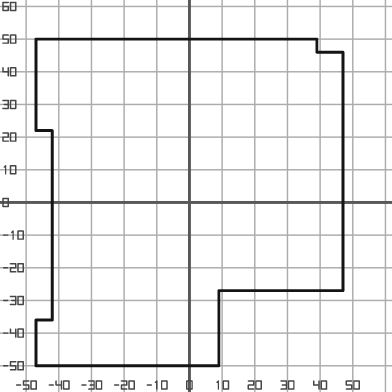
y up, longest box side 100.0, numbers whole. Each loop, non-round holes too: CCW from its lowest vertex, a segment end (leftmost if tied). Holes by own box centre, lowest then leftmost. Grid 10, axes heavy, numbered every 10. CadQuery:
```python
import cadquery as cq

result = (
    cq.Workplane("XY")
    .moveTo(-47.0, -50.0)
    .lineTo(9.0, -50.0)
    .lineTo(9.0, -27.0)
    .lineTo(47.0, -27.0)
    .lineTo(47.0, 46.0)
    .lineTo(39.0, 46.0)
    .lineTo(39.0, 50.0)
    .lineTo(-47.0, 50.0)
    .lineTo(-47.0, 22.0)
    .lineTo(-42.0, 22.0)
    .lineTo(-42.0, -36.0)
    .lineTo(-47.0, -36.0)
    .close()
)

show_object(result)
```